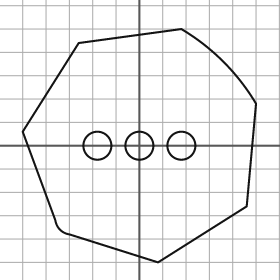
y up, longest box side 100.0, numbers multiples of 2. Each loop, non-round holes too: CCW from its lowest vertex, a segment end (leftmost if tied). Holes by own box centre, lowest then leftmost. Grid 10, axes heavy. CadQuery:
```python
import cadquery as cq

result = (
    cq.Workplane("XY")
    .moveTo(8.0, -50.0)
    .lineTo(46.0, -26.0)
    .lineTo(50.0, 18.0)
    .threePointArc((36.0, 36.0), (18.0, 50.0))
    .lineTo(-26.0, 44.0)
    .lineTo(-50.0, 6.0)
    .lineTo(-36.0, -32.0)
    .threePointArc((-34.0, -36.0), (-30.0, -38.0))
    .close()
    .moveTo(-18.0, 0.0)
    .circle(6.0)
    .moveTo(0.0, 0.0)
    .circle(6.0)
    .moveTo(18.0, 0.0)
    .circle(6.0)
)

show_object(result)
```